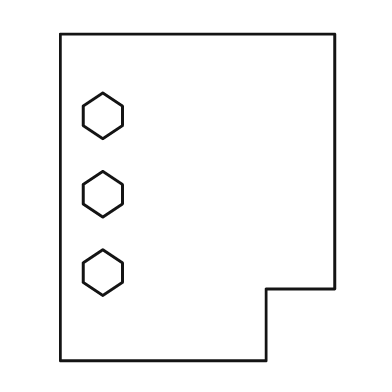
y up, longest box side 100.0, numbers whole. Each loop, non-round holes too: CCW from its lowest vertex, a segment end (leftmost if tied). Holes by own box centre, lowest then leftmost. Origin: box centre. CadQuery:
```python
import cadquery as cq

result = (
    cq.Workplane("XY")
    .moveTo(-42.0, -50.0)
    .lineTo(21.0, -50.0)
    .lineTo(21.0, -28.0)
    .lineTo(42.0, -28.0)
    .lineTo(42.0, 50.0)
    .lineTo(-42.0, 50.0)
    .close()
    .moveTo(-29.0, -30.0)
    .lineTo(-23.0, -26.0)
    .lineTo(-23.0, -20.0)
    .lineTo(-29.0, -16.0)
    .lineTo(-35.0, -20.0)
    .lineTo(-35.0, -26.0)
    .close()
    .moveTo(-29.0, -6.0)
    .lineTo(-23.0, -2.0)
    .lineTo(-23.0, 4.0)
    .lineTo(-29.0, 8.0)
    .lineTo(-35.0, 4.0)
    .lineTo(-35.0, -2.0)
    .close()
    .moveTo(-29.0, 18.0)
    .lineTo(-23.0, 22.0)
    .lineTo(-23.0, 28.0)
    .lineTo(-29.0, 32.0)
    .lineTo(-35.0, 28.0)
    .lineTo(-35.0, 22.0)
    .close()
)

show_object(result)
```